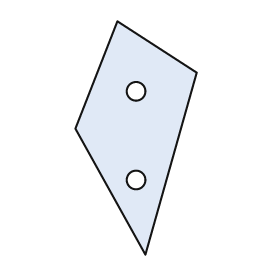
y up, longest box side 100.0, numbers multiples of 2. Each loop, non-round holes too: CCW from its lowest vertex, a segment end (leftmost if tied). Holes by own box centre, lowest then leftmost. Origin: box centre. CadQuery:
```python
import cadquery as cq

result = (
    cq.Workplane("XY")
    .moveTo(4.0, -50.0)
    .lineTo(26.0, 28.0)
    .lineTo(-8.0, 50.0)
    .lineTo(-26.0, 4.0)
    .close()
    .moveTo(0.0, -18.0)
    .circle(4.0)
    .moveTo(0.0, 20.0)
    .circle(4.0)
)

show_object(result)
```